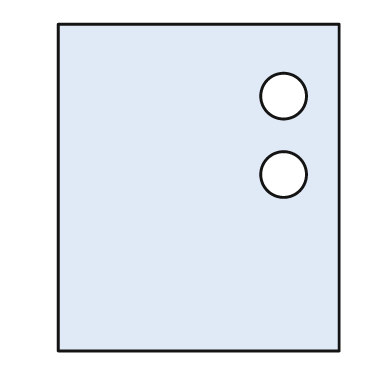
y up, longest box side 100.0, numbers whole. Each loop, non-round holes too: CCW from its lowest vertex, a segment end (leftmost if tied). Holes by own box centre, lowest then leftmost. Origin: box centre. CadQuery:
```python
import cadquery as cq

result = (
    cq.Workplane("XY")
    .moveTo(-43.0, -50.0)
    .lineTo(43.0, -50.0)
    .lineTo(43.0, 50.0)
    .lineTo(-43.0, 50.0)
    .close()
    .moveTo(26.0, 4.0)
    .circle(7.0)
    .moveTo(26.0, 28.0)
    .circle(7.0)
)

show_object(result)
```